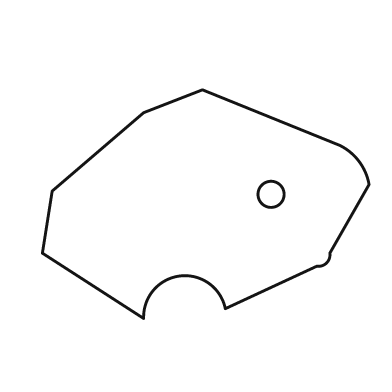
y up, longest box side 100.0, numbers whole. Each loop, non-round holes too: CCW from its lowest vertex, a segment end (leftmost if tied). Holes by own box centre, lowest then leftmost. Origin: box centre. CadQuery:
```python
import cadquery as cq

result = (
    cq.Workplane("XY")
    .moveTo(-19.0, -35.0)
    .threePointArc((-8.0, -22.0), (6.0, -32.0))
    .lineTo(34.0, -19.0)
    .threePointArc((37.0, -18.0), (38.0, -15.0))
    .lineTo(50.0, 6.0)
    .threePointArc((47.0, 13.0), (41.0, 18.0))
    .lineTo(-1.0, 35.0)
    .lineTo(-19.0, 28.0)
    .lineTo(-47.0, 4.0)
    .lineTo(-50.0, -15.0)
    .close()
    .moveTo(20.0, 3.0)
    .circle(4.0)
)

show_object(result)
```